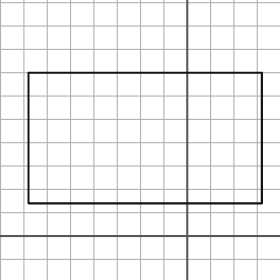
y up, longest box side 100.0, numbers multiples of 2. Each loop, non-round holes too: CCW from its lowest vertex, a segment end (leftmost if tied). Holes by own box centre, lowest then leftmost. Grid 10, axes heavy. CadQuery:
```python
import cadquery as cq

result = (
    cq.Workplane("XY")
    .moveTo(-68.0, 14.0)
    .lineTo(32.0, 14.0)
    .lineTo(32.0, 70.0)
    .lineTo(-68.0, 70.0)
    .close()
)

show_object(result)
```